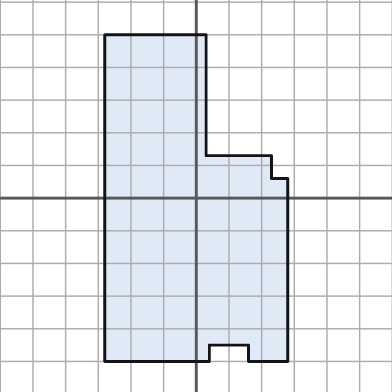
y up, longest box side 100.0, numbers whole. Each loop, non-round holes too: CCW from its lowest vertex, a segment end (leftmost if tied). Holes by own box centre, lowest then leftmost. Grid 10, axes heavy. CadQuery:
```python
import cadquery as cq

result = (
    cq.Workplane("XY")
    .moveTo(-28.0, -50.0)
    .lineTo(4.0, -50.0)
    .lineTo(4.0, -45.0)
    .lineTo(16.0, -45.0)
    .lineTo(16.0, -50.0)
    .lineTo(28.0, -50.0)
    .lineTo(28.0, 6.0)
    .lineTo(23.0, 6.0)
    .lineTo(23.0, 13.0)
    .lineTo(3.0, 13.0)
    .lineTo(3.0, 50.0)
    .lineTo(-28.0, 50.0)
    .close()
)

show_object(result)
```